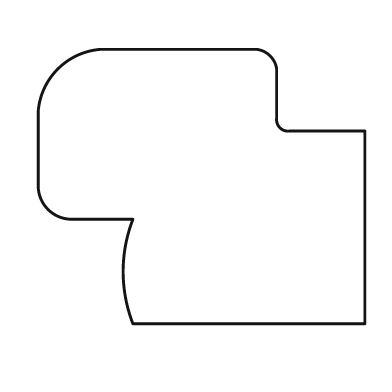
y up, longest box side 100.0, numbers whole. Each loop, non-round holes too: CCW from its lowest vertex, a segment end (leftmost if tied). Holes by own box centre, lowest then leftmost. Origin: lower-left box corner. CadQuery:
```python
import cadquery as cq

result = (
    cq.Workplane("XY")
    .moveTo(29.0, 0.0)
    .lineTo(100.0, 0.0)
    .lineTo(100.0, 59.0)
    .lineTo(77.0, 59.0)
    .threePointArc((74.0, 60.0), (73.0, 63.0))
    .lineTo(73.0, 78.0)
    .threePointArc((71.0, 82.0), (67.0, 84.0))
    .lineTo(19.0, 84.0)
    .threePointArc((6.0, 78.0), (0.0, 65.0))
    .lineTo(0.0, 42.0)
    .threePointArc((3.0, 35.0), (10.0, 32.0))
    .lineTo(29.0, 32.0)
    .threePointArc((26.0, 16.0), (29.0, 0.0))
    .close()
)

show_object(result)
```